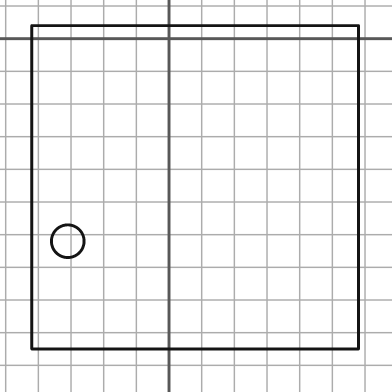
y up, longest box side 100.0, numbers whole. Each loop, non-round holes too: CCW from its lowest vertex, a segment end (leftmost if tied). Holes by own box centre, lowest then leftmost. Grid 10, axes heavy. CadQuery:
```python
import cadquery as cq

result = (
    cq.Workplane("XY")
    .moveTo(-42.0, -95.0)
    .lineTo(58.0, -95.0)
    .lineTo(58.0, 4.0)
    .lineTo(-42.0, 4.0)
    .close()
    .moveTo(-31.0, -62.0)
    .circle(5.0)
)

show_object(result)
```